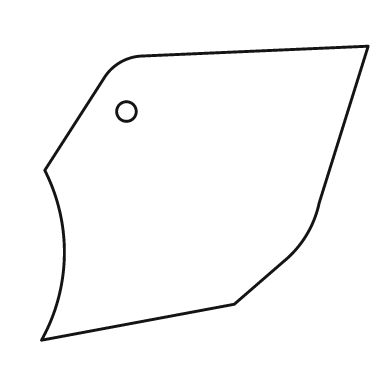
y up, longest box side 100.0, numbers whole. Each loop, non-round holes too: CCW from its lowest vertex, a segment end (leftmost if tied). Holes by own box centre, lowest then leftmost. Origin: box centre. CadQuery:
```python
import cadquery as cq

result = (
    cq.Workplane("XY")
    .moveTo(-50.0, -45.0)
    .lineTo(9.0, -34.0)
    .lineTo(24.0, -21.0)
    .threePointArc((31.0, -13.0), (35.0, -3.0))
    .lineTo(50.0, 45.0)
    .lineTo(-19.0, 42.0)
    .threePointArc((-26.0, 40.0), (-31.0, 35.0))
    .lineTo(-49.0, 7.0)
    .threePointArc((-43.0, -19.0), (-50.0, -45.0))
    .close()
    .moveTo(-24.0, 25.0)
    .circle(3.0)
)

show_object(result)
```